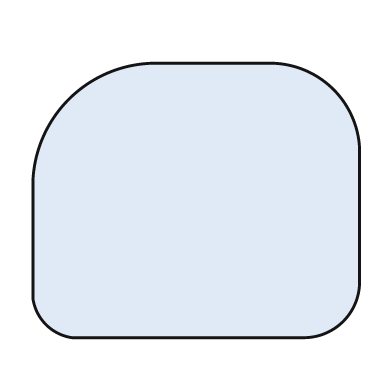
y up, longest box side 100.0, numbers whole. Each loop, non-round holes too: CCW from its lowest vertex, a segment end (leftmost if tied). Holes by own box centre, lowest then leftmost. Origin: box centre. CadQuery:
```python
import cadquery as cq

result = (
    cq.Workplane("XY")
    .moveTo(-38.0, -42.0)
    .lineTo(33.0, -42.0)
    .threePointArc((45.0, -37.0), (50.0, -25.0))
    .lineTo(50.0, 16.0)
    .threePointArc((42.0, 34.0), (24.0, 42.0))
    .lineTo(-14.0, 42.0)
    .threePointArc((-39.0, 31.0), (-50.0, 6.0))
    .lineTo(-50.0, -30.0)
    .threePointArc((-46.0, -38.0), (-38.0, -42.0))
    .close()
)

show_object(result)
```